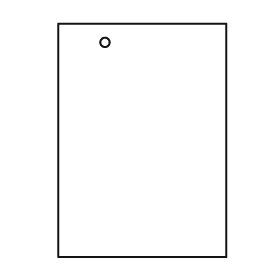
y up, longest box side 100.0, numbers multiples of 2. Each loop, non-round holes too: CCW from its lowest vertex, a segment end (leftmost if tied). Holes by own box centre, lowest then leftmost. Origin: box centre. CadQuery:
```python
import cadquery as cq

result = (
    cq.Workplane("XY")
    .moveTo(-36.0, -50.0)
    .lineTo(36.0, -50.0)
    .lineTo(36.0, 50.0)
    .lineTo(-36.0, 50.0)
    .close()
    .moveTo(-16.0, 42.0)
    .circle(2.0)
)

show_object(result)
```